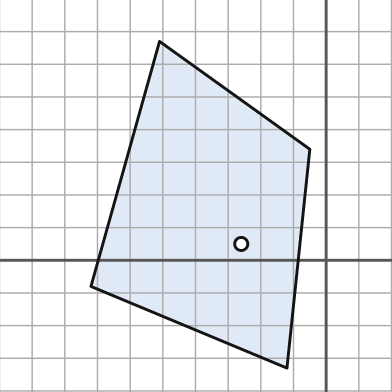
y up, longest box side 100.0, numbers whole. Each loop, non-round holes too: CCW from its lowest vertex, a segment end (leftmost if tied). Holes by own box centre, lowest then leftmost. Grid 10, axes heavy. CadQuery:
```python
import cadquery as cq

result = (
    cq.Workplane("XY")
    .moveTo(-12.0, -33.0)
    .lineTo(-5.0, 34.0)
    .lineTo(-51.0, 67.0)
    .lineTo(-72.0, -8.0)
    .close()
    .moveTo(-26.0, 5.0)
    .circle(2.0)
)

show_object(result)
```